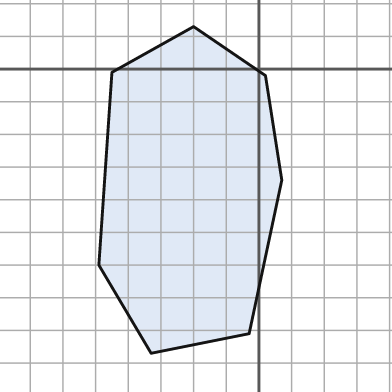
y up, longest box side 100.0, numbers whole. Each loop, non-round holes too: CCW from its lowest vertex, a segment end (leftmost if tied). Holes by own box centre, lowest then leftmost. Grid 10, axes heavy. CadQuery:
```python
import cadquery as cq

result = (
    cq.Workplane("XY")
    .moveTo(-33.0, -87.0)
    .lineTo(-3.0, -81.0)
    .lineTo(7.0, -34.0)
    .lineTo(2.0, -2.0)
    .lineTo(-20.0, 13.0)
    .lineTo(-45.0, -1.0)
    .lineTo(-49.0, -60.0)
    .close()
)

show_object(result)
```